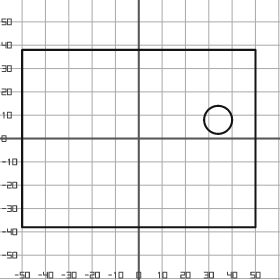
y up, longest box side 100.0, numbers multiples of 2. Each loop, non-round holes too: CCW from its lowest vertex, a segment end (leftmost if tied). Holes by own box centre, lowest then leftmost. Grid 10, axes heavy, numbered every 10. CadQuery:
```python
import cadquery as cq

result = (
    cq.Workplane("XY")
    .moveTo(-50.0, -38.0)
    .lineTo(50.0, -38.0)
    .lineTo(50.0, 38.0)
    .lineTo(-50.0, 38.0)
    .close()
    .moveTo(34.0, 8.0)
    .circle(6.0)
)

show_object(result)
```